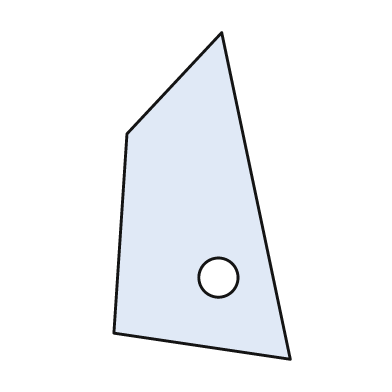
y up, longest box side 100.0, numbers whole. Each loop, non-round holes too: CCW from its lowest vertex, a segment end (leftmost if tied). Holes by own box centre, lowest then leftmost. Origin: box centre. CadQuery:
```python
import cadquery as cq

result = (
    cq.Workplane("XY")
    .moveTo(27.0, -50.0)
    .lineTo(6.0, 50.0)
    .lineTo(-23.0, 19.0)
    .lineTo(-27.0, -42.0)
    .close()
    .moveTo(5.0, -25.0)
    .circle(6.0)
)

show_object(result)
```